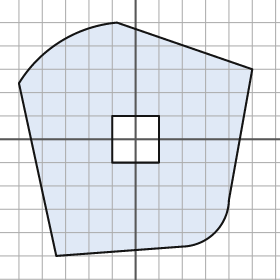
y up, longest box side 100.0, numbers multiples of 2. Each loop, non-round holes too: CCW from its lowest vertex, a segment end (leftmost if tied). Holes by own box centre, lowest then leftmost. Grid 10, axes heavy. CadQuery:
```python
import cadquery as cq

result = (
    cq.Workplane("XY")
    .moveTo(-34.0, -50.0)
    .lineTo(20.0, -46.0)
    .threePointArc((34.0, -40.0), (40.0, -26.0))
    .lineTo(50.0, 30.0)
    .lineTo(-8.0, 50.0)
    .threePointArc((-32.0, 42.0), (-50.0, 24.0))
    .close()
    .moveTo(-10.0, -10.0)
    .lineTo(10.0, -10.0)
    .lineTo(10.0, 10.0)
    .lineTo(-10.0, 10.0)
    .close()
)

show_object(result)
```